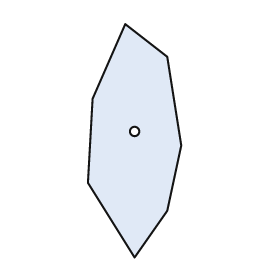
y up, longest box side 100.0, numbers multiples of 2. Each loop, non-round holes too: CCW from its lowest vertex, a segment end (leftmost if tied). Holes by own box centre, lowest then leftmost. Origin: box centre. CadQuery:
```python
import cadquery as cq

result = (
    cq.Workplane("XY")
    .moveTo(0.0, -50.0)
    .lineTo(14.0, -30.0)
    .lineTo(20.0, -2.0)
    .lineTo(14.0, 36.0)
    .lineTo(-4.0, 50.0)
    .lineTo(-18.0, 18.0)
    .lineTo(-20.0, -18.0)
    .close()
    .moveTo(0.0, 4.0)
    .circle(2.0)
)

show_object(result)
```